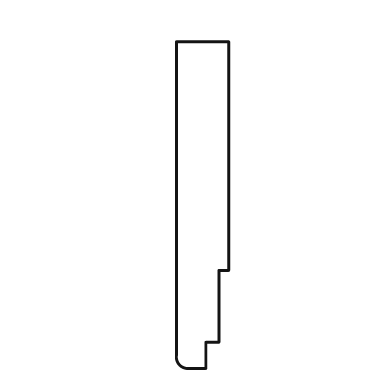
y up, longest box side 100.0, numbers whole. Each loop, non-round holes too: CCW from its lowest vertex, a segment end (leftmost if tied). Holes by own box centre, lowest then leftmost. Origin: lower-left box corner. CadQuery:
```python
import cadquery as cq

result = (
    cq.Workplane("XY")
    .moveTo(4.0, 0.0)
    .lineTo(9.0, 0.0)
    .lineTo(9.0, 8.0)
    .lineTo(13.0, 8.0)
    .lineTo(13.0, 30.0)
    .lineTo(16.0, 30.0)
    .lineTo(16.0, 100.0)
    .lineTo(0.0, 100.0)
    .lineTo(0.0, 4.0)
    .threePointArc((1.0, 1.0), (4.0, 0.0))
    .close()
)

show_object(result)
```